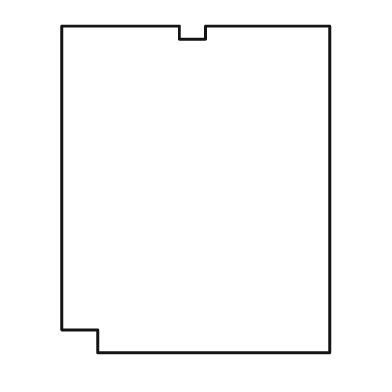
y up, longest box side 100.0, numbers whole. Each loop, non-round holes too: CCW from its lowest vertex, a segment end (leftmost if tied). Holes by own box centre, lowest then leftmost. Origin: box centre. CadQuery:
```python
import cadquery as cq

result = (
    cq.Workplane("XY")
    .moveTo(-30.0, -50.0)
    .lineTo(41.0, -50.0)
    .lineTo(41.0, 50.0)
    .lineTo(3.0, 50.0)
    .lineTo(3.0, 46.0)
    .lineTo(-5.0, 46.0)
    .lineTo(-5.0, 50.0)
    .lineTo(-41.0, 50.0)
    .lineTo(-41.0, -43.0)
    .lineTo(-30.0, -43.0)
    .close()
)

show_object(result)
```